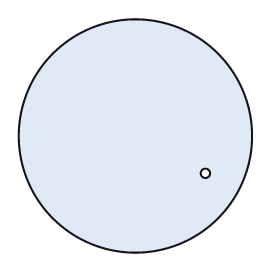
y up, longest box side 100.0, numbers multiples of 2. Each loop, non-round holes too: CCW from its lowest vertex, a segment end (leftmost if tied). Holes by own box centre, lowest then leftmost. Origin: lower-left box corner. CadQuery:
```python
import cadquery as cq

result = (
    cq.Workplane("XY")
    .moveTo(50.0, 50.0)
    .circle(50.0)
    .moveTo(80.0, 34.0)
    .circle(2.0)
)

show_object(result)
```